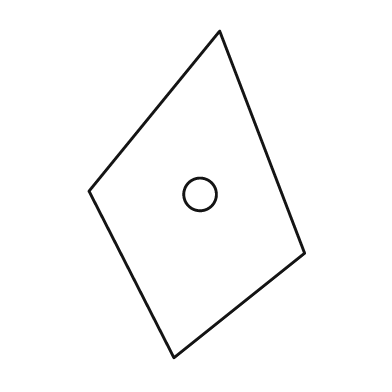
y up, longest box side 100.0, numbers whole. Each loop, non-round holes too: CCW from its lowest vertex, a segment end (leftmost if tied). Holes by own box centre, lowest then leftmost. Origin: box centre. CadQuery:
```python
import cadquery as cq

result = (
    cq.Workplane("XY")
    .moveTo(-7.0, -50.0)
    .lineTo(33.0, -18.0)
    .lineTo(7.0, 50.0)
    .lineTo(-33.0, 1.0)
    .close()
    .moveTo(1.0, 0.0)
    .circle(5.0)
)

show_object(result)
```